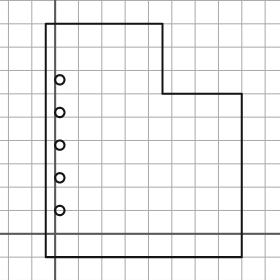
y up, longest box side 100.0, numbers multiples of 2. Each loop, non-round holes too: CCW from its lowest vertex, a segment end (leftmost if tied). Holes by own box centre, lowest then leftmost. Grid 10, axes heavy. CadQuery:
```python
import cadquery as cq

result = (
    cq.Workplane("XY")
    .moveTo(-4.0, -10.0)
    .lineTo(80.0, -10.0)
    .lineTo(80.0, 60.0)
    .lineTo(46.0, 60.0)
    .lineTo(46.0, 90.0)
    .lineTo(-4.0, 90.0)
    .close()
    .moveTo(2.0, 10.0)
    .circle(2.0)
    .moveTo(2.0, 24.0)
    .circle(2.0)
    .moveTo(2.0, 38.0)
    .circle(2.0)
    .moveTo(2.0, 52.0)
    .circle(2.0)
    .moveTo(2.0, 66.0)
    .circle(2.0)
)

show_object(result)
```